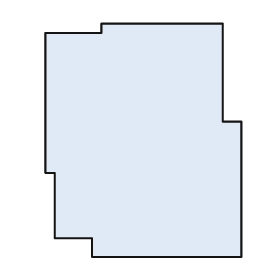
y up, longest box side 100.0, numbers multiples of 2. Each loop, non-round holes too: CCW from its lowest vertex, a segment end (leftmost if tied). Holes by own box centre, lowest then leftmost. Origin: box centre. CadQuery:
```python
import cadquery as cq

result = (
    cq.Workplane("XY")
    .moveTo(-22.0, -50.0)
    .lineTo(42.0, -50.0)
    .lineTo(42.0, 8.0)
    .lineTo(34.0, 8.0)
    .lineTo(34.0, 50.0)
    .lineTo(-18.0, 50.0)
    .lineTo(-18.0, 46.0)
    .lineTo(-42.0, 46.0)
    .lineTo(-42.0, -14.0)
    .lineTo(-38.0, -14.0)
    .lineTo(-38.0, -42.0)
    .lineTo(-22.0, -42.0)
    .close()
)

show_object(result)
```